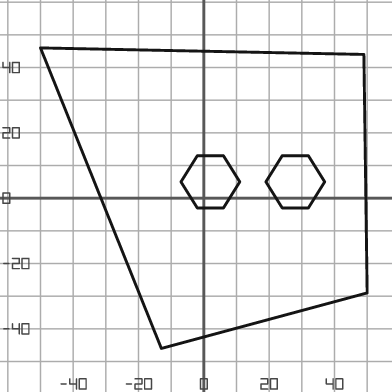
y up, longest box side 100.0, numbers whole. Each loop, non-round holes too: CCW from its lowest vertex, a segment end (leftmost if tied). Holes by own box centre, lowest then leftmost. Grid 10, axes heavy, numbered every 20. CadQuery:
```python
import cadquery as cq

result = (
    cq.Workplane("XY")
    .moveTo(-13.0, -46.0)
    .lineTo(50.0, -29.0)
    .lineTo(49.0, 44.0)
    .lineTo(-50.0, 46.0)
    .close()
    .moveTo(-2.0, -3.0)
    .lineTo(6.0, -3.0)
    .lineTo(11.0, 5.0)
    .lineTo(6.0, 13.0)
    .lineTo(-2.0, 13.0)
    .lineTo(-7.0, 5.0)
    .close()
    .moveTo(24.0, -3.0)
    .lineTo(32.0, -3.0)
    .lineTo(37.0, 5.0)
    .lineTo(32.0, 13.0)
    .lineTo(24.0, 13.0)
    .lineTo(19.0, 5.0)
    .close()
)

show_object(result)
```